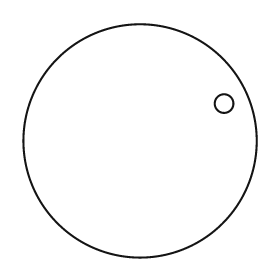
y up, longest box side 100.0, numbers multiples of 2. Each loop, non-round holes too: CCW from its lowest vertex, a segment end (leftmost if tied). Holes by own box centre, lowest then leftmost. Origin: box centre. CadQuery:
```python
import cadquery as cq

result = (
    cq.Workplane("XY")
    .moveTo(0.0, 0.0)
    .circle(50.0)
    .moveTo(36.0, 16.0)
    .circle(4.0)
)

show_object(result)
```